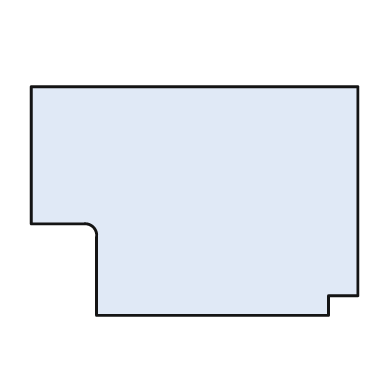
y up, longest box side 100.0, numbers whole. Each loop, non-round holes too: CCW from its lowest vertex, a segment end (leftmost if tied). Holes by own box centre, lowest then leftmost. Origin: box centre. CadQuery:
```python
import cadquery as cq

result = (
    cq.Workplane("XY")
    .moveTo(-30.0, -35.0)
    .lineTo(41.0, -35.0)
    .lineTo(41.0, -29.0)
    .lineTo(50.0, -29.0)
    .lineTo(50.0, 35.0)
    .lineTo(-50.0, 35.0)
    .lineTo(-50.0, -7.0)
    .lineTo(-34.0, -7.0)
    .threePointArc((-31.0, -8.0), (-30.0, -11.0))
    .close()
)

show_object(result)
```